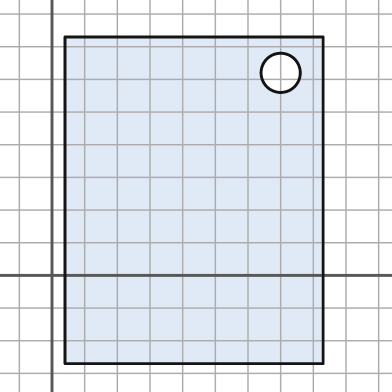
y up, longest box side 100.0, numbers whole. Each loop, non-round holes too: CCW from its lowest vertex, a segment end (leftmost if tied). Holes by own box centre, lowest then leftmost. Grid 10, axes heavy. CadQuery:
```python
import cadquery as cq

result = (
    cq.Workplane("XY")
    .moveTo(4.0, -27.0)
    .lineTo(83.0, -27.0)
    .lineTo(83.0, 73.0)
    .lineTo(4.0, 73.0)
    .close()
    .moveTo(70.0, 62.0)
    .circle(6.0)
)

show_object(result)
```